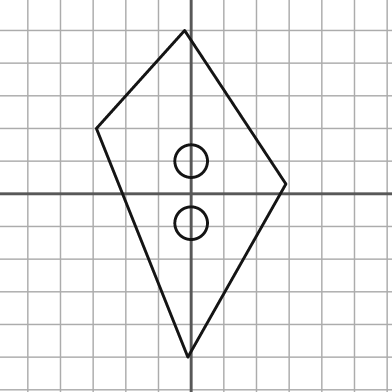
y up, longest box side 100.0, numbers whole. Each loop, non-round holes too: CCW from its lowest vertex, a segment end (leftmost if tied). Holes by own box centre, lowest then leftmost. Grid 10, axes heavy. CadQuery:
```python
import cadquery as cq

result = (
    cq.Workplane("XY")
    .moveTo(-1.0, -50.0)
    .lineTo(29.0, 3.0)
    .lineTo(-2.0, 50.0)
    .lineTo(-29.0, 20.0)
    .close()
    .moveTo(0.0, -9.0)
    .circle(5.0)
    .moveTo(0.0, 10.0)
    .circle(5.0)
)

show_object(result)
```